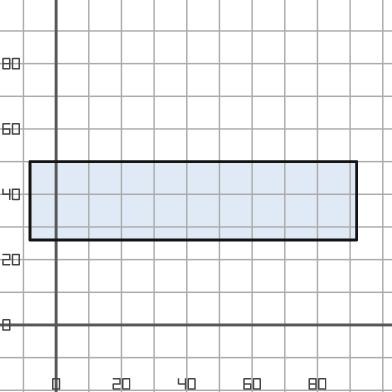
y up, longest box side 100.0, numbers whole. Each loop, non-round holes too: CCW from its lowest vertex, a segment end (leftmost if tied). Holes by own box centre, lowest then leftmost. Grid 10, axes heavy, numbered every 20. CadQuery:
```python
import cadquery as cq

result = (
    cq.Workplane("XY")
    .moveTo(-8.0, 26.0)
    .lineTo(92.0, 26.0)
    .lineTo(92.0, 50.0)
    .lineTo(-8.0, 50.0)
    .close()
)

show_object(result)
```